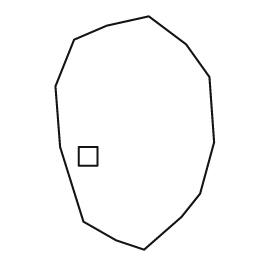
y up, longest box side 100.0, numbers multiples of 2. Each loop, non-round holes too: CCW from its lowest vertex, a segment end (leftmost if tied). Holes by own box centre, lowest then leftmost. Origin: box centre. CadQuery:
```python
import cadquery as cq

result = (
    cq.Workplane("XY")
    .moveTo(4.0, -50.0)
    .lineTo(20.0, -36.0)
    .lineTo(28.0, -26.0)
    .lineTo(34.0, -4.0)
    .lineTo(32.0, 24.0)
    .lineTo(22.0, 38.0)
    .lineTo(6.0, 50.0)
    .lineTo(-12.0, 46.0)
    .lineTo(-26.0, 40.0)
    .lineTo(-34.0, 20.0)
    .lineTo(-32.0, -6.0)
    .lineTo(-22.0, -38.0)
    .lineTo(-8.0, -46.0)
    .close()
    .moveTo(-24.0, -14.0)
    .lineTo(-16.0, -14.0)
    .lineTo(-16.0, -6.0)
    .lineTo(-24.0, -6.0)
    .close()
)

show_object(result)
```